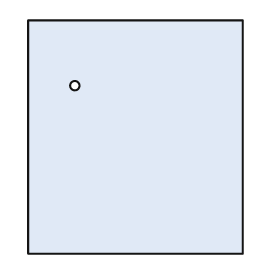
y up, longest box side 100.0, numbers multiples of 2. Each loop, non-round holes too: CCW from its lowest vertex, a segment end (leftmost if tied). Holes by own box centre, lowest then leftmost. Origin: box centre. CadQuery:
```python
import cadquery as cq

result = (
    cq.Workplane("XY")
    .moveTo(-46.0, -50.0)
    .lineTo(46.0, -50.0)
    .lineTo(46.0, 50.0)
    .lineTo(-46.0, 50.0)
    .close()
    .moveTo(-26.0, 22.0)
    .circle(2.0)
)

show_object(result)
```